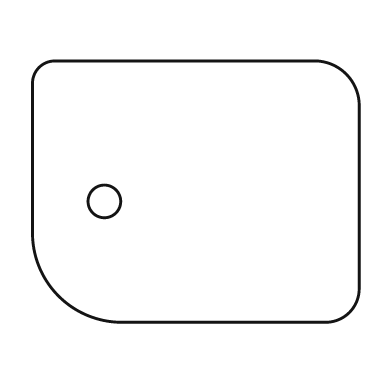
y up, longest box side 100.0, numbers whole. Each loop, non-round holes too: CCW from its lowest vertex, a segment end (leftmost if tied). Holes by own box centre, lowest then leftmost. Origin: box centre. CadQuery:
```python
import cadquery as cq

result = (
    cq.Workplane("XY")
    .moveTo(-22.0, -40.0)
    .lineTo(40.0, -40.0)
    .threePointArc((47.0, -37.0), (50.0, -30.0))
    .lineTo(50.0, 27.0)
    .threePointArc((46.0, 36.0), (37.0, 40.0))
    .lineTo(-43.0, 40.0)
    .threePointArc((-48.0, 38.0), (-50.0, 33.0))
    .lineTo(-50.0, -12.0)
    .threePointArc((-42.0, -32.0), (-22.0, -40.0))
    .close()
    .moveTo(-28.0, -3.0)
    .circle(5.0)
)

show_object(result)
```